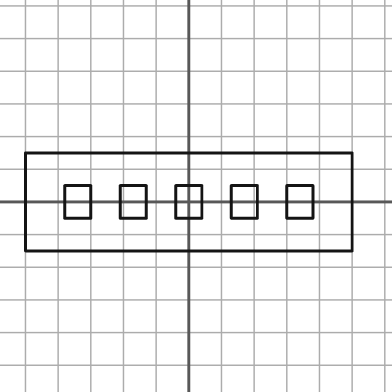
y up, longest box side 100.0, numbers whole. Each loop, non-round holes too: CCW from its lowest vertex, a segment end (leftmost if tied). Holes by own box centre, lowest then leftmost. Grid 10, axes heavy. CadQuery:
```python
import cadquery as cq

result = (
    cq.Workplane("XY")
    .moveTo(-50.0, -15.0)
    .lineTo(50.0, -15.0)
    .lineTo(50.0, 15.0)
    .lineTo(-50.0, 15.0)
    .close()
    .moveTo(-38.0, -5.0)
    .lineTo(-30.0, -5.0)
    .lineTo(-30.0, 5.0)
    .lineTo(-38.0, 5.0)
    .close()
    .moveTo(-21.0, -5.0)
    .lineTo(-13.0, -5.0)
    .lineTo(-13.0, 5.0)
    .lineTo(-21.0, 5.0)
    .close()
    .moveTo(-4.0, -5.0)
    .lineTo(4.0, -5.0)
    .lineTo(4.0, 5.0)
    .lineTo(-4.0, 5.0)
    .close()
    .moveTo(13.0, -5.0)
    .lineTo(21.0, -5.0)
    .lineTo(21.0, 5.0)
    .lineTo(13.0, 5.0)
    .close()
    .moveTo(30.0, -5.0)
    .lineTo(38.0, -5.0)
    .lineTo(38.0, 5.0)
    .lineTo(30.0, 5.0)
    .close()
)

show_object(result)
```